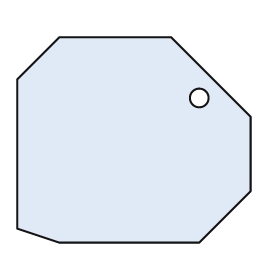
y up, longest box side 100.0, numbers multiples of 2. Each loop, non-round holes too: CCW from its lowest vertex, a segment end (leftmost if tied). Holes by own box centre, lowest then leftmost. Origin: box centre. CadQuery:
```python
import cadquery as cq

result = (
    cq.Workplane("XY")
    .moveTo(-32.0, -44.0)
    .lineTo(28.0, -44.0)
    .lineTo(50.0, -22.0)
    .lineTo(50.0, 10.0)
    .lineTo(16.0, 44.0)
    .lineTo(-32.0, 44.0)
    .lineTo(-50.0, 26.0)
    .lineTo(-50.0, -38.0)
    .close()
    .moveTo(28.0, 18.0)
    .circle(4.0)
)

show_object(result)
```